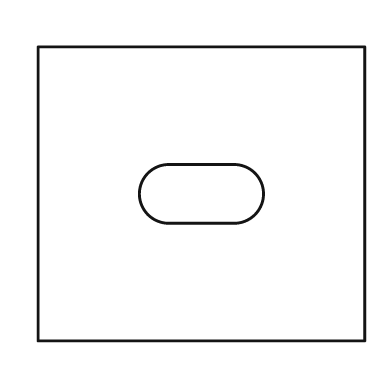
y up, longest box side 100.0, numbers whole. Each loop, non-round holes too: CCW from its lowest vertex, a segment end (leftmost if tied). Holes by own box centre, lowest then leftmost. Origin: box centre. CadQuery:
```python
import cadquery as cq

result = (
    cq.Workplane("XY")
    .moveTo(-50.0, -45.0)
    .lineTo(50.0, -45.0)
    .lineTo(50.0, 45.0)
    .lineTo(-50.0, 45.0)
    .close()
    .moveTo(-10.0, -9.0)
    .lineTo(10.0, -9.0)
    .threePointArc((19.0, 0.0), (10.0, 9.0))
    .lineTo(-10.0, 9.0)
    .threePointArc((-19.0, 0.0), (-10.0, -9.0))
    .close()
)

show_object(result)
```